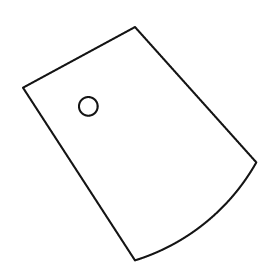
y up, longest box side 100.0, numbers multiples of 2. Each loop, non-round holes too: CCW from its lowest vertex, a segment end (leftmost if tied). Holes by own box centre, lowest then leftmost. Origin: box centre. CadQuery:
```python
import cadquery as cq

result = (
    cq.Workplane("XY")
    .moveTo(-2.0, -50.0)
    .threePointArc((28.0, -34.0), (50.0, -8.0))
    .lineTo(-2.0, 50.0)
    .lineTo(-50.0, 24.0)
    .close()
    .moveTo(-22.0, 16.0)
    .circle(4.0)
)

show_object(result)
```